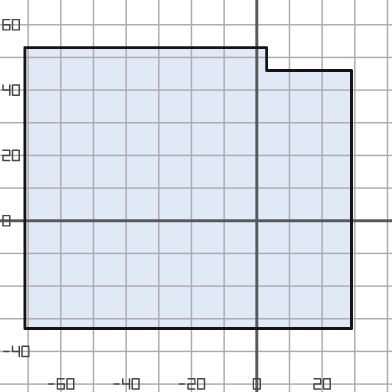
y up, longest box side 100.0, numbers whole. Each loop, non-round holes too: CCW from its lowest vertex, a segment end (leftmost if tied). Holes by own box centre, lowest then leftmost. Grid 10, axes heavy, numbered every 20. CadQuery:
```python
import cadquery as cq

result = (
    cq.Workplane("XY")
    .moveTo(-71.0, -33.0)
    .lineTo(29.0, -33.0)
    .lineTo(29.0, 46.0)
    .lineTo(3.0, 46.0)
    .lineTo(3.0, 53.0)
    .lineTo(-71.0, 53.0)
    .close()
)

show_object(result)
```